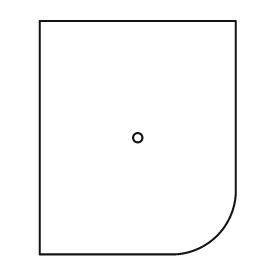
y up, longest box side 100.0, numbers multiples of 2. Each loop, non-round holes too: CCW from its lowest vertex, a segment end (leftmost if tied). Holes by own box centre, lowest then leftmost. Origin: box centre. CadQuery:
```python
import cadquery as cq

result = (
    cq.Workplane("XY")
    .moveTo(-42.0, -50.0)
    .lineTo(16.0, -50.0)
    .threePointArc((34.0, -42.0), (42.0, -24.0))
    .lineTo(42.0, 50.0)
    .lineTo(-42.0, 50.0)
    .close()
    .moveTo(0.0, 0.0)
    .circle(2.0)
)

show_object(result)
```